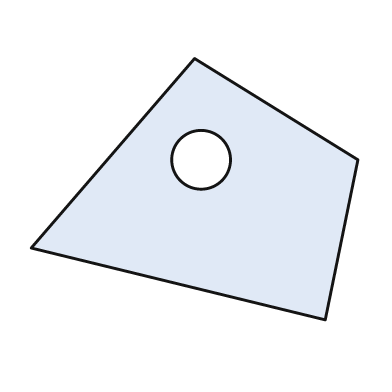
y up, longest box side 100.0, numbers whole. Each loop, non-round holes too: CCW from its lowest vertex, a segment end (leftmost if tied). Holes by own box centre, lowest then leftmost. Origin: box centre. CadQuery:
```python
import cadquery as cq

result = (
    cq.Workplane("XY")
    .moveTo(40.0, -40.0)
    .lineTo(50.0, 9.0)
    .lineTo(0.0, 40.0)
    .lineTo(-50.0, -18.0)
    .close()
    .moveTo(2.0, 9.0)
    .circle(9.0)
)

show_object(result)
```